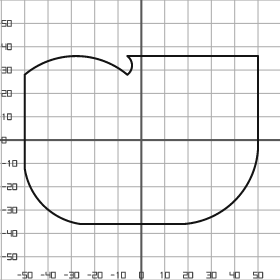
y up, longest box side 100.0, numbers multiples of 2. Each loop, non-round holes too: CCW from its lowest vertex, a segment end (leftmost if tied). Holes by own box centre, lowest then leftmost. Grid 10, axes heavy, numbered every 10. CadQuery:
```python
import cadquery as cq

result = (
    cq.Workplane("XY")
    .moveTo(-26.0, -36.0)
    .lineTo(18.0, -36.0)
    .threePointArc((40.0, -26.0), (50.0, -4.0))
    .lineTo(50.0, 36.0)
    .lineTo(-6.0, 36.0)
    .threePointArc((-4.0, 32.0), (-6.0, 28.0))
    .threePointArc((-28.0, 36.0), (-50.0, 28.0))
    .lineTo(-50.0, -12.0)
    .threePointArc((-42.0, -28.0), (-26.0, -36.0))
    .close()
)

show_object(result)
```